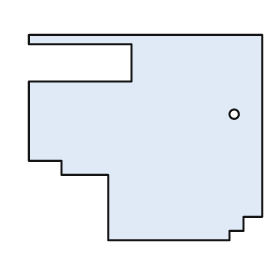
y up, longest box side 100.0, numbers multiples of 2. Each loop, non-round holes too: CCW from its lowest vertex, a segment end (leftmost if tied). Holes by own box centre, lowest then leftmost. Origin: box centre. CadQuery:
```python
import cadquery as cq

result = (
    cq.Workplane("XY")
    .moveTo(-16.0, -44.0)
    .lineTo(36.0, -44.0)
    .lineTo(36.0, -40.0)
    .lineTo(42.0, -40.0)
    .lineTo(42.0, -34.0)
    .lineTo(50.0, -34.0)
    .lineTo(50.0, 44.0)
    .lineTo(-50.0, 44.0)
    .lineTo(-50.0, 40.0)
    .lineTo(-6.0, 40.0)
    .lineTo(-6.0, 24.0)
    .lineTo(-50.0, 24.0)
    .lineTo(-50.0, -10.0)
    .lineTo(-36.0, -10.0)
    .lineTo(-36.0, -16.0)
    .lineTo(-16.0, -16.0)
    .close()
    .moveTo(38.0, 10.0)
    .circle(2.0)
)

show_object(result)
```